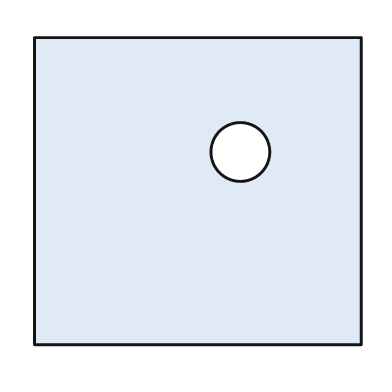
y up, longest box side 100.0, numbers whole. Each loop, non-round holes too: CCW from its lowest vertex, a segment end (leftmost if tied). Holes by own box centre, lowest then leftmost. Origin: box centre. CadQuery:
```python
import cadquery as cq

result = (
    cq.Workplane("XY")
    .moveTo(-50.0, -47.0)
    .lineTo(50.0, -47.0)
    .lineTo(50.0, 47.0)
    .lineTo(-50.0, 47.0)
    .close()
    .moveTo(13.0, 12.0)
    .circle(9.0)
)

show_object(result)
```